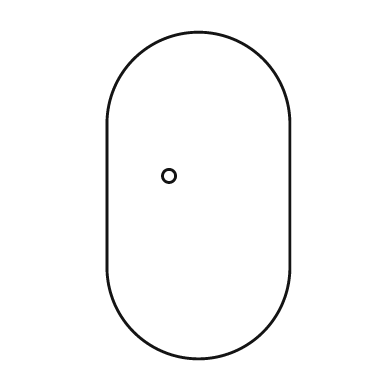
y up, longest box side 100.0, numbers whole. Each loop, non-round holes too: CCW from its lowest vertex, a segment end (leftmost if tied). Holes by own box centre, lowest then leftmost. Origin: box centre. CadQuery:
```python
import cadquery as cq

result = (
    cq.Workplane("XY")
    .moveTo(-28.0, -22.0)
    .threePointArc((0.0, -50.0), (28.0, -22.0))
    .lineTo(28.0, 22.0)
    .threePointArc((0.0, 50.0), (-28.0, 22.0))
    .close()
    .moveTo(-9.0, 6.0)
    .circle(2.0)
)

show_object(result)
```